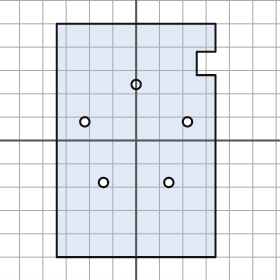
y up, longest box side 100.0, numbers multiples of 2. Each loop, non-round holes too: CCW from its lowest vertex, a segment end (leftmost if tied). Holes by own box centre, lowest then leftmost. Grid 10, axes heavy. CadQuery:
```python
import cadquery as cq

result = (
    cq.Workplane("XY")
    .moveTo(-34.0, -50.0)
    .lineTo(34.0, -50.0)
    .lineTo(34.0, 28.0)
    .lineTo(26.0, 28.0)
    .lineTo(26.0, 38.0)
    .lineTo(34.0, 38.0)
    .lineTo(34.0, 50.0)
    .lineTo(-34.0, 50.0)
    .close()
    .moveTo(-14.0, -18.0)
    .circle(2.0)
    .moveTo(14.0, -18.0)
    .circle(2.0)
    .moveTo(-22.0, 8.0)
    .circle(2.0)
    .moveTo(22.0, 8.0)
    .circle(2.0)
    .moveTo(0.0, 24.0)
    .circle(2.0)
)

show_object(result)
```